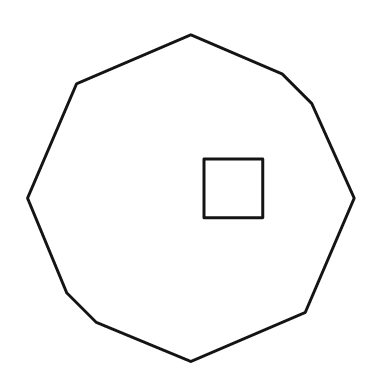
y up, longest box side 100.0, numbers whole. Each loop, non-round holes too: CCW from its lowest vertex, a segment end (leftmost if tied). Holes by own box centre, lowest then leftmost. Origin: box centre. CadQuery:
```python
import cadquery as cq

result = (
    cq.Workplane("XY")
    .moveTo(0.0, -50.0)
    .lineTo(35.0, -35.0)
    .lineTo(50.0, 0.0)
    .lineTo(37.0, 29.0)
    .lineTo(28.0, 38.0)
    .lineTo(0.0, 50.0)
    .lineTo(-35.0, 35.0)
    .lineTo(-50.0, 0.0)
    .lineTo(-38.0, -29.0)
    .lineTo(-29.0, -38.0)
    .close()
    .moveTo(4.0, -6.0)
    .lineTo(22.0, -6.0)
    .lineTo(22.0, 12.0)
    .lineTo(4.0, 12.0)
    .close()
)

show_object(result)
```